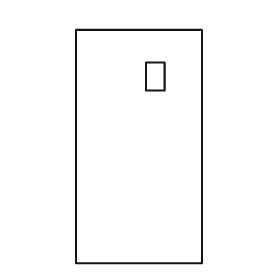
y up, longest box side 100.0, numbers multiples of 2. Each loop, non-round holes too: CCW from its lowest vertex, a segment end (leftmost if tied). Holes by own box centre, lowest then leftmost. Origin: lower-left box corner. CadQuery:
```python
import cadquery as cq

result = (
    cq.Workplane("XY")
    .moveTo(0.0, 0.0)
    .lineTo(54.0, 0.0)
    .lineTo(54.0, 100.0)
    .lineTo(0.0, 100.0)
    .close()
    .moveTo(30.0, 74.0)
    .lineTo(38.0, 74.0)
    .lineTo(38.0, 86.0)
    .lineTo(30.0, 86.0)
    .close()
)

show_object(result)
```